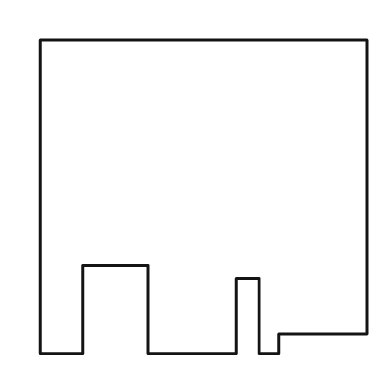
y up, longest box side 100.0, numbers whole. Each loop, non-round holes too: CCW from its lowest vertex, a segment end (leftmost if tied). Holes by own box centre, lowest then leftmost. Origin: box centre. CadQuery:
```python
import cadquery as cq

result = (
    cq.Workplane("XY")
    .moveTo(-50.0, -48.0)
    .lineTo(-37.0, -48.0)
    .lineTo(-37.0, -21.0)
    .lineTo(-17.0, -21.0)
    .lineTo(-17.0, -48.0)
    .lineTo(10.0, -48.0)
    .lineTo(10.0, -25.0)
    .lineTo(17.0, -25.0)
    .lineTo(17.0, -48.0)
    .lineTo(23.0, -48.0)
    .lineTo(23.0, -42.0)
    .lineTo(50.0, -42.0)
    .lineTo(50.0, 48.0)
    .lineTo(-50.0, 48.0)
    .close()
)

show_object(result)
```